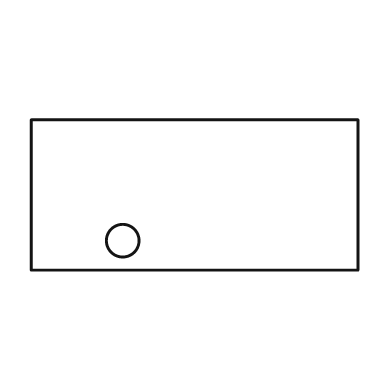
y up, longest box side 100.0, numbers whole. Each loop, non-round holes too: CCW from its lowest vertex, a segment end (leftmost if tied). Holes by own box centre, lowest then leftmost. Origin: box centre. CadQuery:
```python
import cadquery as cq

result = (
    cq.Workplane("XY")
    .moveTo(-50.0, -23.0)
    .lineTo(50.0, -23.0)
    .lineTo(50.0, 23.0)
    .lineTo(-50.0, 23.0)
    .close()
    .moveTo(-22.0, -14.0)
    .circle(5.0)
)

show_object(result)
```